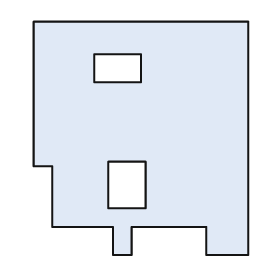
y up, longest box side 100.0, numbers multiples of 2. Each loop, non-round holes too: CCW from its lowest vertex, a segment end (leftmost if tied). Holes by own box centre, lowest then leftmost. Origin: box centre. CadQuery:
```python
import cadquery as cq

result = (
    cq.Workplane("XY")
    .moveTo(-12.0, -50.0)
    .lineTo(-4.0, -50.0)
    .lineTo(-4.0, -38.0)
    .lineTo(28.0, -38.0)
    .lineTo(28.0, -50.0)
    .lineTo(46.0, -50.0)
    .lineTo(46.0, 50.0)
    .lineTo(-46.0, 50.0)
    .lineTo(-46.0, -12.0)
    .lineTo(-38.0, -12.0)
    .lineTo(-38.0, -38.0)
    .lineTo(-12.0, -38.0)
    .close()
    .moveTo(-14.0, -30.0)
    .lineTo(2.0, -30.0)
    .lineTo(2.0, -10.0)
    .lineTo(-14.0, -10.0)
    .close()
    .moveTo(-20.0, 24.0)
    .lineTo(0.0, 24.0)
    .lineTo(0.0, 36.0)
    .lineTo(-20.0, 36.0)
    .close()
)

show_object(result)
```